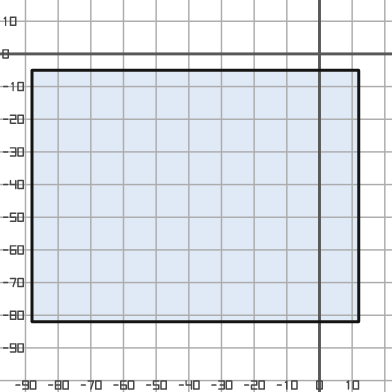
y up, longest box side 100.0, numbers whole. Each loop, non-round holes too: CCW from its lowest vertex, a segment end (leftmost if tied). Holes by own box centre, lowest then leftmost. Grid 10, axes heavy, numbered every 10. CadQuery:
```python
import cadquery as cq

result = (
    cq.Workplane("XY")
    .moveTo(-88.0, -82.0)
    .lineTo(12.0, -82.0)
    .lineTo(12.0, -5.0)
    .lineTo(-88.0, -5.0)
    .close()
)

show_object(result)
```